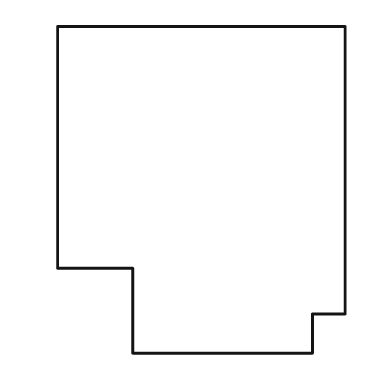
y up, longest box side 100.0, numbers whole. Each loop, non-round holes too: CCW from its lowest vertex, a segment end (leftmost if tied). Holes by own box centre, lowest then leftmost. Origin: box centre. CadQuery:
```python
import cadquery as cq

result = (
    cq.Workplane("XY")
    .moveTo(-21.0, -50.0)
    .lineTo(34.0, -50.0)
    .lineTo(34.0, -38.0)
    .lineTo(44.0, -38.0)
    .lineTo(44.0, 50.0)
    .lineTo(-44.0, 50.0)
    .lineTo(-44.0, -24.0)
    .lineTo(-21.0, -24.0)
    .close()
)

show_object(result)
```